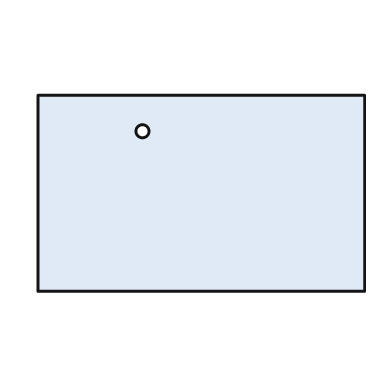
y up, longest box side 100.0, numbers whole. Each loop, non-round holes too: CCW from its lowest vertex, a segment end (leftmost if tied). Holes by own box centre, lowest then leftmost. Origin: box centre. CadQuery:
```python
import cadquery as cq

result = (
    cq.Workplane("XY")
    .moveTo(-50.0, -30.0)
    .lineTo(50.0, -30.0)
    .lineTo(50.0, 30.0)
    .lineTo(-50.0, 30.0)
    .close()
    .moveTo(-18.0, 19.0)
    .circle(2.0)
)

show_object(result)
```